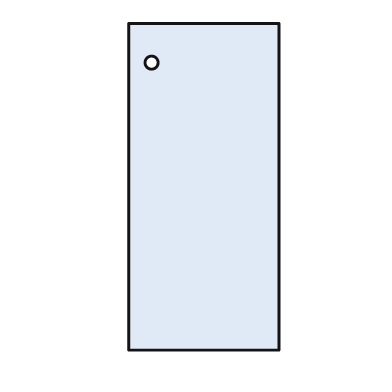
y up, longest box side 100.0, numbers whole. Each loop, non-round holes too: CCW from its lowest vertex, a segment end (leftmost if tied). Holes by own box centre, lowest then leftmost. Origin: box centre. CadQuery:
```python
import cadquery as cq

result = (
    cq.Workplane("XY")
    .moveTo(-23.0, -50.0)
    .lineTo(23.0, -50.0)
    .lineTo(23.0, 50.0)
    .lineTo(-23.0, 50.0)
    .close()
    .moveTo(-16.0, 38.0)
    .circle(2.0)
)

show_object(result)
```